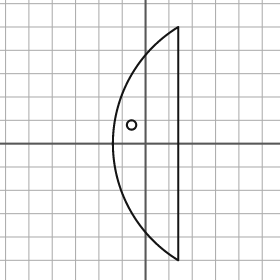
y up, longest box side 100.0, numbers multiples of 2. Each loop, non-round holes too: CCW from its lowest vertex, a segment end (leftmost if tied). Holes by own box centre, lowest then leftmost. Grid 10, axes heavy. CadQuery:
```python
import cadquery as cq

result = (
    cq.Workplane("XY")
    .moveTo(14.0, -50.0)
    .lineTo(14.0, 50.0)
    .threePointArc((-14.0, 0.0), (14.0, -50.0))
    .close()
    .moveTo(-6.0, 8.0)
    .circle(2.0)
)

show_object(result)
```